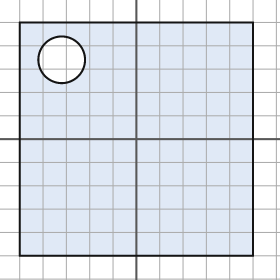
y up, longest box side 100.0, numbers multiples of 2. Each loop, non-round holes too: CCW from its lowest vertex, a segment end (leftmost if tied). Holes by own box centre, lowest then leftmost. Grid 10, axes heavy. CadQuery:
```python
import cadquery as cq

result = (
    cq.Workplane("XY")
    .moveTo(-50.0, -50.0)
    .lineTo(50.0, -50.0)
    .lineTo(50.0, 50.0)
    .lineTo(-50.0, 50.0)
    .close()
    .moveTo(-32.0, 34.0)
    .circle(10.0)
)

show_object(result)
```